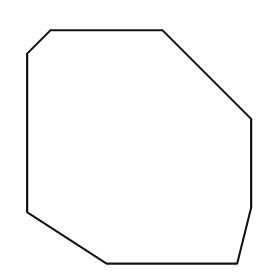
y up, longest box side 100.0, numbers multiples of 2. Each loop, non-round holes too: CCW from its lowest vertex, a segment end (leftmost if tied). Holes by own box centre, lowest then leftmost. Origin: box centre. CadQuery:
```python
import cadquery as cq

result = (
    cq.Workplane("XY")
    .moveTo(-14.0, -50.0)
    .lineTo(42.0, -50.0)
    .lineTo(48.0, -26.0)
    .lineTo(48.0, 12.0)
    .lineTo(10.0, 50.0)
    .lineTo(-38.0, 50.0)
    .lineTo(-48.0, 40.0)
    .lineTo(-48.0, -28.0)
    .close()
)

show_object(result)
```